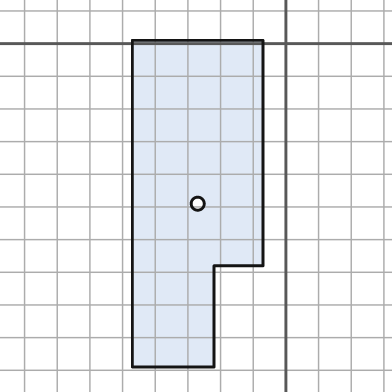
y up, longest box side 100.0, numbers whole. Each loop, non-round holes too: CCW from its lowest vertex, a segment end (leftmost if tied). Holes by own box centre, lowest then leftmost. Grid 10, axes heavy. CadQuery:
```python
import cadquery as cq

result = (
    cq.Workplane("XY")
    .moveTo(-47.0, -99.0)
    .lineTo(-22.0, -99.0)
    .lineTo(-22.0, -68.0)
    .lineTo(-7.0, -68.0)
    .lineTo(-7.0, 1.0)
    .lineTo(-47.0, 1.0)
    .close()
    .moveTo(-27.0, -49.0)
    .circle(2.0)
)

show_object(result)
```